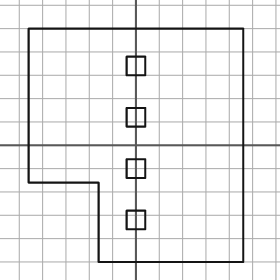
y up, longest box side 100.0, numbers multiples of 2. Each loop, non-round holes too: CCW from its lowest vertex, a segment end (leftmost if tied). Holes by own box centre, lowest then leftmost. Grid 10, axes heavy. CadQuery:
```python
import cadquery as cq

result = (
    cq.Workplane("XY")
    .moveTo(-16.0, -50.0)
    .lineTo(46.0, -50.0)
    .lineTo(46.0, 50.0)
    .lineTo(-46.0, 50.0)
    .lineTo(-46.0, -16.0)
    .lineTo(-16.0, -16.0)
    .close()
    .moveTo(-4.0, -36.0)
    .lineTo(4.0, -36.0)
    .lineTo(4.0, -28.0)
    .lineTo(-4.0, -28.0)
    .close()
    .moveTo(-4.0, -14.0)
    .lineTo(4.0, -14.0)
    .lineTo(4.0, -6.0)
    .lineTo(-4.0, -6.0)
    .close()
    .moveTo(-4.0, 8.0)
    .lineTo(4.0, 8.0)
    .lineTo(4.0, 16.0)
    .lineTo(-4.0, 16.0)
    .close()
    .moveTo(-4.0, 30.0)
    .lineTo(4.0, 30.0)
    .lineTo(4.0, 38.0)
    .lineTo(-4.0, 38.0)
    .close()
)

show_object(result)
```